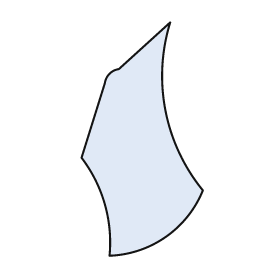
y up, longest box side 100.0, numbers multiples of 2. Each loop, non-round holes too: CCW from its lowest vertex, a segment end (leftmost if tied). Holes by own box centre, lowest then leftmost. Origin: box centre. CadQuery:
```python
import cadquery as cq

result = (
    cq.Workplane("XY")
    .moveTo(-14.0, -50.0)
    .threePointArc((10.0, -42.0), (26.0, -22.0))
    .threePointArc((10.0, 12.0), (12.0, 50.0))
    .lineTo(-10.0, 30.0)
    .threePointArc((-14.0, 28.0), (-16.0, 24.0))
    .lineTo(-26.0, -8.0)
    .threePointArc((-16.0, -28.0), (-14.0, -50.0))
    .close()
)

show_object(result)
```